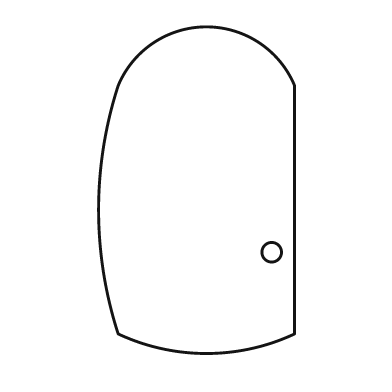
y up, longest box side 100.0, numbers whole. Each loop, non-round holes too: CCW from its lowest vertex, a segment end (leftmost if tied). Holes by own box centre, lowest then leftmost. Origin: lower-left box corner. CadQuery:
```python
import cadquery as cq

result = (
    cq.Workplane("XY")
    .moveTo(6.0, 6.0)
    .threePointArc((33.0, 0.0), (60.0, 6.0))
    .lineTo(60.0, 82.0)
    .threePointArc((33.0, 100.0), (6.0, 82.0))
    .threePointArc((0.0, 44.0), (6.0, 6.0))
    .close()
    .moveTo(53.0, 31.0)
    .circle(3.0)
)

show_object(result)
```